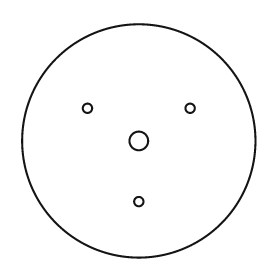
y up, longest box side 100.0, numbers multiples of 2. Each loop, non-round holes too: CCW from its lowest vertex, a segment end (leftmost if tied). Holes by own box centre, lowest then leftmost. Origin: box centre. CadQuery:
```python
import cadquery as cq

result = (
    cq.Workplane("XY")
    .moveTo(0.0, 0.0)
    .circle(50.0)
    .moveTo(0.0, -26.0)
    .circle(2.0)
    .moveTo(0.0, 0.0)
    .circle(4.0)
    .moveTo(-22.0, 14.0)
    .circle(2.0)
    .moveTo(22.0, 14.0)
    .circle(2.0)
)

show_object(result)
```